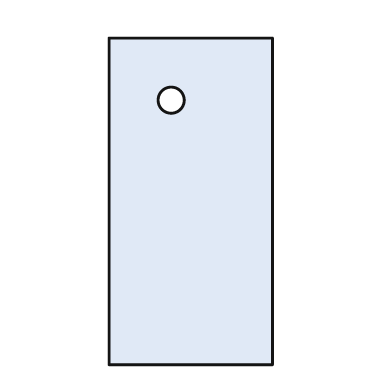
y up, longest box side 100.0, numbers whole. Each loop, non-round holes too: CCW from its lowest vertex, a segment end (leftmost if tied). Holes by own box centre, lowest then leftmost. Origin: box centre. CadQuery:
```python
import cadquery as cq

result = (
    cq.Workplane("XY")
    .moveTo(-25.0, -50.0)
    .lineTo(25.0, -50.0)
    .lineTo(25.0, 50.0)
    .lineTo(-25.0, 50.0)
    .close()
    .moveTo(-6.0, 31.0)
    .circle(4.0)
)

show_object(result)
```